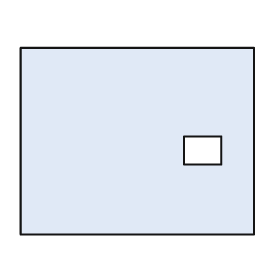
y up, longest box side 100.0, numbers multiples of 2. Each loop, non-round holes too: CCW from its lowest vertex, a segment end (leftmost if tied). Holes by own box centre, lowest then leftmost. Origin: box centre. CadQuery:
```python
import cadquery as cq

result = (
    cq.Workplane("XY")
    .moveTo(-50.0, -40.0)
    .lineTo(50.0, -40.0)
    .lineTo(50.0, 40.0)
    .lineTo(-50.0, 40.0)
    .close()
    .moveTo(20.0, -10.0)
    .lineTo(36.0, -10.0)
    .lineTo(36.0, 2.0)
    .lineTo(20.0, 2.0)
    .close()
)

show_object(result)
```